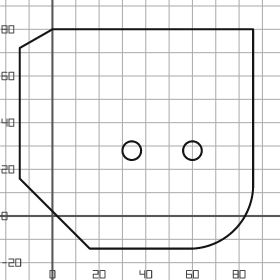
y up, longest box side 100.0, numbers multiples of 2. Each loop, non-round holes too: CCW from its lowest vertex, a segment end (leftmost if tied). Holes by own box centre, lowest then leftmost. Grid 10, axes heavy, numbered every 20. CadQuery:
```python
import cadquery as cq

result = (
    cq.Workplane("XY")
    .moveTo(16.0, -14.0)
    .lineTo(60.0, -14.0)
    .threePointArc((78.0, -6.0), (86.0, 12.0))
    .lineTo(86.0, 80.0)
    .lineTo(0.0, 80.0)
    .lineTo(-14.0, 72.0)
    .lineTo(-14.0, 16.0)
    .close()
    .moveTo(34.0, 28.0)
    .circle(4.0)
    .moveTo(60.0, 28.0)
    .circle(4.0)
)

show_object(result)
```